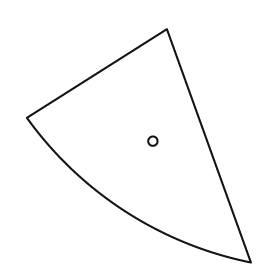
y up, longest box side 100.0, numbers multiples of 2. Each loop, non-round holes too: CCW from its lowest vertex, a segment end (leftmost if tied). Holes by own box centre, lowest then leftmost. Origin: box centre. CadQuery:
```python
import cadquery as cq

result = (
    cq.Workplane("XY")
    .moveTo(48.0, -50.0)
    .lineTo(12.0, 50.0)
    .lineTo(-48.0, 12.0)
    .threePointArc((-6.0, -28.0), (48.0, -50.0))
    .close()
    .moveTo(6.0, 2.0)
    .circle(2.0)
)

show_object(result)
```